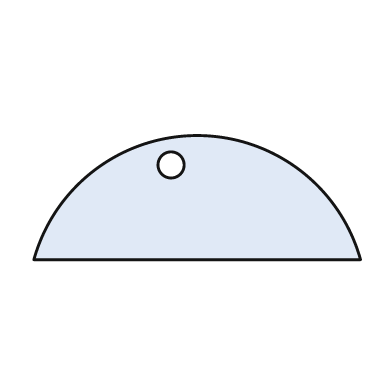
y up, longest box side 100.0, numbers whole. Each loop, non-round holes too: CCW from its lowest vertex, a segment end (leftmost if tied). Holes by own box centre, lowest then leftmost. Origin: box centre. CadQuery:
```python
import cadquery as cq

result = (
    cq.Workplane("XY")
    .moveTo(-50.0, -19.0)
    .lineTo(50.0, -19.0)
    .threePointArc((0.0, 19.0), (-50.0, -19.0))
    .close()
    .moveTo(-8.0, 10.0)
    .circle(4.0)
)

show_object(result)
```